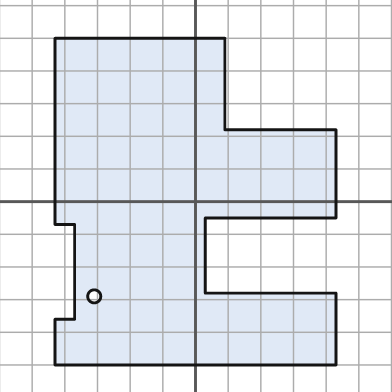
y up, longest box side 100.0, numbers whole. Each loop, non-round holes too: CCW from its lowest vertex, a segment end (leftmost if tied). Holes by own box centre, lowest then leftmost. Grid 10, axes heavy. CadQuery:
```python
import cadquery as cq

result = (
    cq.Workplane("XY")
    .moveTo(-43.0, -50.0)
    .lineTo(43.0, -50.0)
    .lineTo(43.0, -28.0)
    .lineTo(3.0, -28.0)
    .lineTo(3.0, -5.0)
    .lineTo(43.0, -5.0)
    .lineTo(43.0, 22.0)
    .lineTo(9.0, 22.0)
    .lineTo(9.0, 50.0)
    .lineTo(-43.0, 50.0)
    .lineTo(-43.0, -7.0)
    .lineTo(-37.0, -7.0)
    .lineTo(-37.0, -36.0)
    .lineTo(-43.0, -36.0)
    .close()
    .moveTo(-31.0, -29.0)
    .circle(2.0)
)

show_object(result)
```